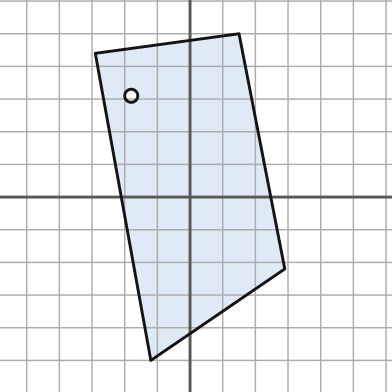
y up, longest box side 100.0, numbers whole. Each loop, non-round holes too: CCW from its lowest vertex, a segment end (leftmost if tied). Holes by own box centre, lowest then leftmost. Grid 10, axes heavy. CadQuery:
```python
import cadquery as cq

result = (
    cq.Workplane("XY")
    .moveTo(-12.0, -50.0)
    .lineTo(29.0, -22.0)
    .lineTo(15.0, 50.0)
    .lineTo(-29.0, 44.0)
    .close()
    .moveTo(-18.0, 31.0)
    .circle(2.0)
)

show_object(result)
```